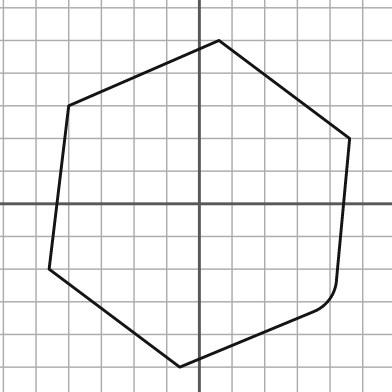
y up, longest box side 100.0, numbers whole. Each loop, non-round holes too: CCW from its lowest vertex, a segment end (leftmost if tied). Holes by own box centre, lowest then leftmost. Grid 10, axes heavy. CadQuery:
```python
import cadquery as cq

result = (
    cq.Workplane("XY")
    .moveTo(-6.0, -50.0)
    .lineTo(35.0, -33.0)
    .threePointArc((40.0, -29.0), (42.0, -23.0))
    .lineTo(46.0, 20.0)
    .lineTo(6.0, 50.0)
    .lineTo(-40.0, 30.0)
    .lineTo(-46.0, -20.0)
    .close()
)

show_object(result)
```